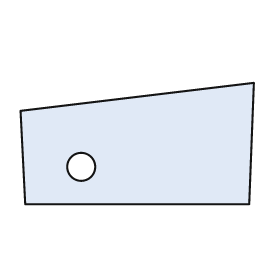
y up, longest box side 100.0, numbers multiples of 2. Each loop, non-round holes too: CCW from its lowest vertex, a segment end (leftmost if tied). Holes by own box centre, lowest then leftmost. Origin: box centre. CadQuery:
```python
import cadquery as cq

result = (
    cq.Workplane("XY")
    .moveTo(-48.0, -26.0)
    .lineTo(48.0, -26.0)
    .lineTo(50.0, 26.0)
    .lineTo(-50.0, 14.0)
    .close()
    .moveTo(-24.0, -10.0)
    .circle(6.0)
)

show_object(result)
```